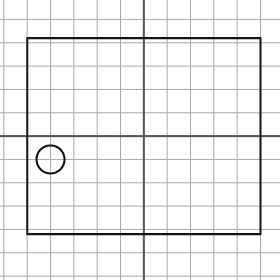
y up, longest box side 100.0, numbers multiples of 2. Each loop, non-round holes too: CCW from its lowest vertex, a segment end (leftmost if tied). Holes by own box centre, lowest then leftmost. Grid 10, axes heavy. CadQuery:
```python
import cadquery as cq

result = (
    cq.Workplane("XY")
    .moveTo(-50.0, -42.0)
    .lineTo(50.0, -42.0)
    .lineTo(50.0, 42.0)
    .lineTo(-50.0, 42.0)
    .close()
    .moveTo(-40.0, -10.0)
    .circle(6.0)
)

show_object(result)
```